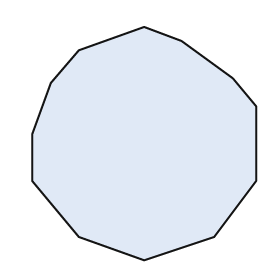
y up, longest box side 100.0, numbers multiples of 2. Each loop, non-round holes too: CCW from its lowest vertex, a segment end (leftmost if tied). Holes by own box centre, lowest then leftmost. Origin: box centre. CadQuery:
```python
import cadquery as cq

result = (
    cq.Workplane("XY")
    .moveTo(0.0, -50.0)
    .lineTo(30.0, -40.0)
    .lineTo(48.0, -16.0)
    .lineTo(48.0, 16.0)
    .lineTo(38.0, 28.0)
    .lineTo(16.0, 44.0)
    .lineTo(0.0, 50.0)
    .lineTo(-28.0, 40.0)
    .lineTo(-40.0, 26.0)
    .lineTo(-48.0, 4.0)
    .lineTo(-48.0, -16.0)
    .lineTo(-28.0, -40.0)
    .close()
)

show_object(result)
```